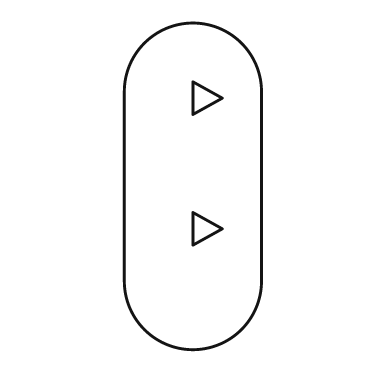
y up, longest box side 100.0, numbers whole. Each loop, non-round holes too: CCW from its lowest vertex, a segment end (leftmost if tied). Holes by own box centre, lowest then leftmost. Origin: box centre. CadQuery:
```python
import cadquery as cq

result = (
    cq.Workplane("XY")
    .moveTo(-21.0, -29.0)
    .threePointArc((0.0, -50.0), (21.0, -29.0))
    .lineTo(21.0, 29.0)
    .threePointArc((0.0, 50.0), (-21.0, 29.0))
    .close()
    .moveTo(0.0, -18.0)
    .lineTo(9.0, -13.0)
    .lineTo(0.0, -8.0)
    .close()
    .moveTo(0.0, 22.0)
    .lineTo(9.0, 27.0)
    .lineTo(0.0, 32.0)
    .close()
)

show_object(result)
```